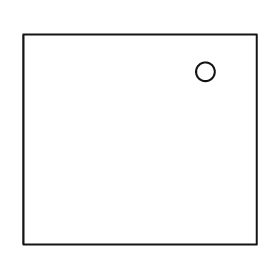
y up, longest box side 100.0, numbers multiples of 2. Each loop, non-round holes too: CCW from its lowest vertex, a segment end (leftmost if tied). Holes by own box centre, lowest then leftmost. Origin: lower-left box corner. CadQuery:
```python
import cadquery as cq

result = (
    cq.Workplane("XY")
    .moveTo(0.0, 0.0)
    .lineTo(100.0, 0.0)
    .lineTo(100.0, 90.0)
    .lineTo(0.0, 90.0)
    .close()
    .moveTo(78.0, 74.0)
    .circle(4.0)
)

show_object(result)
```